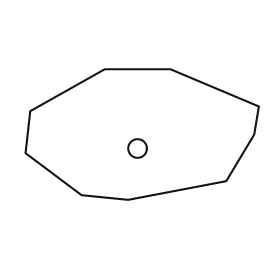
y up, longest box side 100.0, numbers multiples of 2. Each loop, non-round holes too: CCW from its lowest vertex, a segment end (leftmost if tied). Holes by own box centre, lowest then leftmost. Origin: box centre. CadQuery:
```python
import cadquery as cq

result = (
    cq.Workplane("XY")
    .moveTo(-6.0, -28.0)
    .lineTo(36.0, -20.0)
    .lineTo(48.0, 0.0)
    .lineTo(50.0, 12.0)
    .lineTo(12.0, 28.0)
    .lineTo(-16.0, 28.0)
    .lineTo(-48.0, 10.0)
    .lineTo(-50.0, -8.0)
    .lineTo(-26.0, -26.0)
    .close()
    .moveTo(-2.0, -6.0)
    .circle(4.0)
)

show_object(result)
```